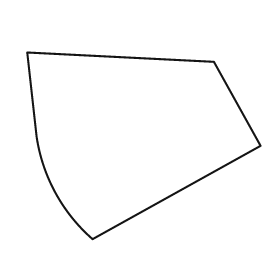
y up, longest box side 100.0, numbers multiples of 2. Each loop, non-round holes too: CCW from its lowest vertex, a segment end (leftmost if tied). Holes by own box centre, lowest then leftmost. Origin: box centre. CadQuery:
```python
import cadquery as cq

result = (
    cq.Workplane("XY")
    .moveTo(-22.0, -40.0)
    .lineTo(50.0, 0.0)
    .lineTo(30.0, 36.0)
    .lineTo(-50.0, 40.0)
    .lineTo(-46.0, 4.0)
    .threePointArc((-38.0, -20.0), (-22.0, -40.0))
    .close()
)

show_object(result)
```